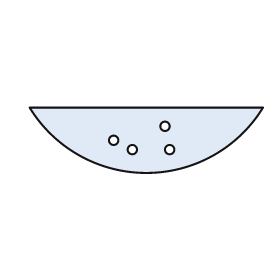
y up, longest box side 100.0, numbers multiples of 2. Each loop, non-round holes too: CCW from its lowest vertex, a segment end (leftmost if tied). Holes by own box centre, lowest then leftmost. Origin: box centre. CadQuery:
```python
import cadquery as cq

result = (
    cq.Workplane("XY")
    .moveTo(-50.0, 14.0)
    .threePointArc((0.0, -14.0), (50.0, 14.0))
    .close()
    .moveTo(-6.0, -4.0)
    .circle(2.0)
    .moveTo(10.0, -4.0)
    .circle(2.0)
    .moveTo(-14.0, 0.0)
    .circle(2.0)
    .moveTo(8.0, 6.0)
    .circle(2.0)
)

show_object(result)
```